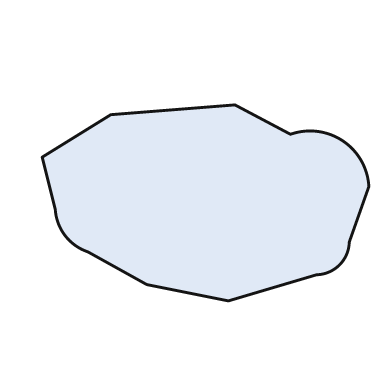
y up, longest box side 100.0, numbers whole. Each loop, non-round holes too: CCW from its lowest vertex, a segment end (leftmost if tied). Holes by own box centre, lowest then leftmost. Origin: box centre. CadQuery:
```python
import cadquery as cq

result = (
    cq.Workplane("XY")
    .moveTo(7.0, -30.0)
    .lineTo(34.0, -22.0)
    .threePointArc((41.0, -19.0), (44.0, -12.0))
    .lineTo(50.0, 5.0)
    .threePointArc((42.0, 19.0), (26.0, 21.0))
    .lineTo(9.0, 30.0)
    .lineTo(-29.0, 27.0)
    .lineTo(-50.0, 14.0)
    .lineTo(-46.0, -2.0)
    .threePointArc((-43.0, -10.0), (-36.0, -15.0))
    .lineTo(-18.0, -25.0)
    .close()
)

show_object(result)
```